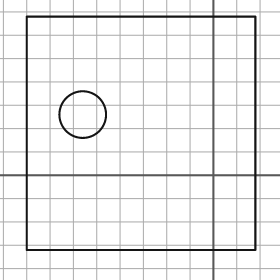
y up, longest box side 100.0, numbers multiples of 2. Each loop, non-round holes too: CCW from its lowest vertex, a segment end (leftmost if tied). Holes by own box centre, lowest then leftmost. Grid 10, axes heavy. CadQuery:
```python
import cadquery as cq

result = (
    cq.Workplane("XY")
    .moveTo(-80.0, -32.0)
    .lineTo(18.0, -32.0)
    .lineTo(18.0, 68.0)
    .lineTo(-80.0, 68.0)
    .close()
    .moveTo(-56.0, 26.0)
    .circle(10.0)
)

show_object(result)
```